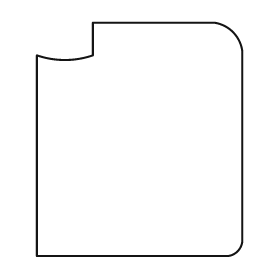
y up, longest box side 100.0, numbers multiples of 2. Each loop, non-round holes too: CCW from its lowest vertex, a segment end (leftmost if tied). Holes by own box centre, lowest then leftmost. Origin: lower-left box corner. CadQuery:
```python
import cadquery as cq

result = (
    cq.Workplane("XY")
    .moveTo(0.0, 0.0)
    .lineTo(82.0, 0.0)
    .threePointArc((86.0, 2.0), (88.0, 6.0))
    .lineTo(88.0, 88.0)
    .threePointArc((84.0, 96.0), (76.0, 100.0))
    .lineTo(24.0, 100.0)
    .lineTo(24.0, 86.0)
    .threePointArc((12.0, 84.0), (0.0, 86.0))
    .close()
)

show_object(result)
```